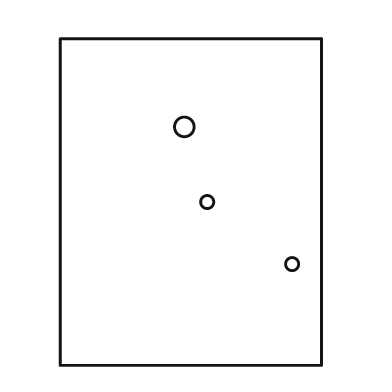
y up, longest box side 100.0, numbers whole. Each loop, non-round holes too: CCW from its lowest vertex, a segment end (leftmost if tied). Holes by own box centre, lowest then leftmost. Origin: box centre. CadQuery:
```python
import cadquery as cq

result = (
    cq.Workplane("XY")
    .moveTo(-40.0, -50.0)
    .lineTo(40.0, -50.0)
    .lineTo(40.0, 50.0)
    .lineTo(-40.0, 50.0)
    .close()
    .moveTo(31.0, -19.0)
    .circle(2.0)
    .moveTo(5.0, 0.0)
    .circle(2.0)
    .moveTo(-2.0, 23.0)
    .circle(3.0)
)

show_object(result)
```